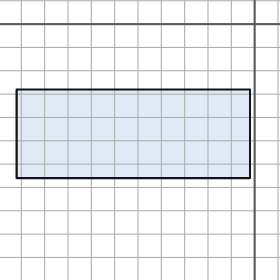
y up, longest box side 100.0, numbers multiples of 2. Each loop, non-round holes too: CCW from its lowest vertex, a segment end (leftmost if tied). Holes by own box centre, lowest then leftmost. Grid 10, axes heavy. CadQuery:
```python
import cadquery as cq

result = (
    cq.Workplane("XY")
    .moveTo(-102.0, -66.0)
    .lineTo(-2.0, -66.0)
    .lineTo(-2.0, -28.0)
    .lineTo(-102.0, -28.0)
    .close()
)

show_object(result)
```